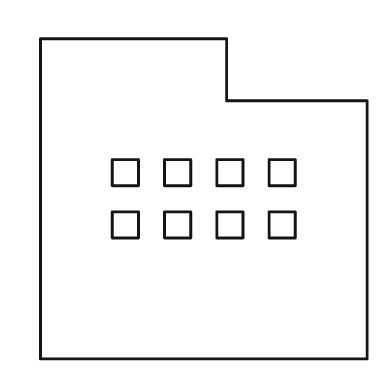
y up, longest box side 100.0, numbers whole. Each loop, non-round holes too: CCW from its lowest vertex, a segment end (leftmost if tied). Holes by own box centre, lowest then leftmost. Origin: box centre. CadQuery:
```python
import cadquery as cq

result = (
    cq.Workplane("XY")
    .moveTo(-50.0, -49.0)
    .lineTo(50.0, -49.0)
    .lineTo(50.0, 30.0)
    .lineTo(7.0, 30.0)
    .lineTo(7.0, 49.0)
    .lineTo(-50.0, 49.0)
    .close()
    .moveTo(-28.0, -12.0)
    .lineTo(-20.0, -12.0)
    .lineTo(-20.0, -4.0)
    .lineTo(-28.0, -4.0)
    .close()
    .moveTo(-12.0, -12.0)
    .lineTo(-4.0, -12.0)
    .lineTo(-4.0, -4.0)
    .lineTo(-12.0, -4.0)
    .close()
    .moveTo(4.0, -12.0)
    .lineTo(12.0, -12.0)
    .lineTo(12.0, -4.0)
    .lineTo(4.0, -4.0)
    .close()
    .moveTo(20.0, -12.0)
    .lineTo(28.0, -12.0)
    .lineTo(28.0, -4.0)
    .lineTo(20.0, -4.0)
    .close()
    .moveTo(-28.0, 4.0)
    .lineTo(-20.0, 4.0)
    .lineTo(-20.0, 12.0)
    .lineTo(-28.0, 12.0)
    .close()
    .moveTo(-12.0, 4.0)
    .lineTo(-4.0, 4.0)
    .lineTo(-4.0, 12.0)
    .lineTo(-12.0, 12.0)
    .close()
    .moveTo(4.0, 4.0)
    .lineTo(12.0, 4.0)
    .lineTo(12.0, 12.0)
    .lineTo(4.0, 12.0)
    .close()
    .moveTo(20.0, 4.0)
    .lineTo(28.0, 4.0)
    .lineTo(28.0, 12.0)
    .lineTo(20.0, 12.0)
    .close()
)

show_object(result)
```